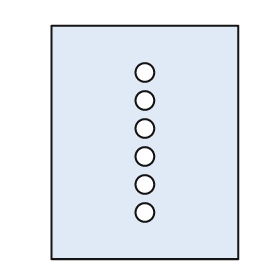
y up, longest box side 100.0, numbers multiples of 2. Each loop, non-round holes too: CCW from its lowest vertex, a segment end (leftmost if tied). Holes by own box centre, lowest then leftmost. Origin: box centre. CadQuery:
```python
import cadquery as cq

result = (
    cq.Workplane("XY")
    .moveTo(-40.0, -50.0)
    .lineTo(40.0, -50.0)
    .lineTo(40.0, 50.0)
    .lineTo(-40.0, 50.0)
    .close()
    .moveTo(0.0, -30.0)
    .circle(4.0)
    .moveTo(0.0, -18.0)
    .circle(4.0)
    .moveTo(0.0, -6.0)
    .circle(4.0)
    .moveTo(0.0, 6.0)
    .circle(4.0)
    .moveTo(0.0, 18.0)
    .circle(4.0)
    .moveTo(0.0, 30.0)
    .circle(4.0)
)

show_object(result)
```